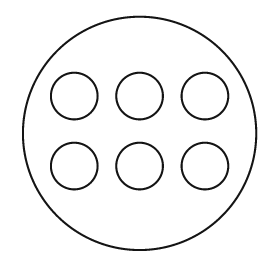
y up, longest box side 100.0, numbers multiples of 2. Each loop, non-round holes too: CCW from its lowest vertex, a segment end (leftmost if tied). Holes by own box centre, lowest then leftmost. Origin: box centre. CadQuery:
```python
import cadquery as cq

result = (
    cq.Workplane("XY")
    .moveTo(0.0, 0.0)
    .circle(50.0)
    .moveTo(-28.0, -14.0)
    .circle(10.0)
    .moveTo(0.0, -14.0)
    .circle(10.0)
    .moveTo(28.0, -14.0)
    .circle(10.0)
    .moveTo(-28.0, 16.0)
    .circle(10.0)
    .moveTo(0.0, 16.0)
    .circle(10.0)
    .moveTo(28.0, 16.0)
    .circle(10.0)
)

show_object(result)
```